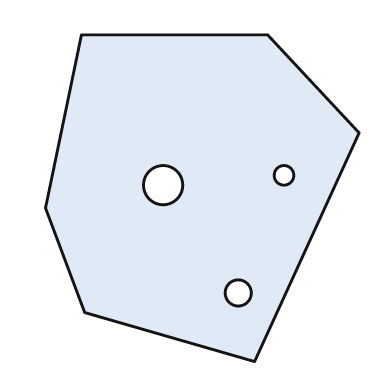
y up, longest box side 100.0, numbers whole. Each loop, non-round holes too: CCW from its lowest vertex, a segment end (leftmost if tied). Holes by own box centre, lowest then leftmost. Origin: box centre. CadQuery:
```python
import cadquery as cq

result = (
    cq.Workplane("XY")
    .moveTo(16.0, -50.0)
    .lineTo(48.0, 20.0)
    .lineTo(20.0, 50.0)
    .lineTo(-37.0, 50.0)
    .lineTo(-48.0, -3.0)
    .lineTo(-36.0, -35.0)
    .close()
    .moveTo(11.0, -29.0)
    .circle(4.0)
    .moveTo(-12.0, 4.0)
    .circle(6.0)
    .moveTo(25.0, 7.0)
    .circle(3.0)
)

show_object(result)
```